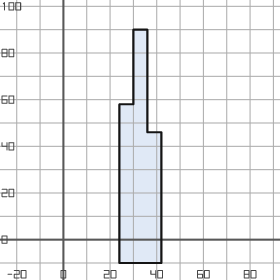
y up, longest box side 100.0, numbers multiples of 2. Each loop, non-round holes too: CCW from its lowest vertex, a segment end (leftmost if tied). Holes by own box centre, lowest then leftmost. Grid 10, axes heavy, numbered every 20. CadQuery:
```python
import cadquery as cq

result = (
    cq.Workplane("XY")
    .moveTo(24.0, -10.0)
    .lineTo(42.0, -10.0)
    .lineTo(42.0, 46.0)
    .lineTo(36.0, 46.0)
    .lineTo(36.0, 90.0)
    .lineTo(30.0, 90.0)
    .lineTo(30.0, 58.0)
    .lineTo(24.0, 58.0)
    .close()
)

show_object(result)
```